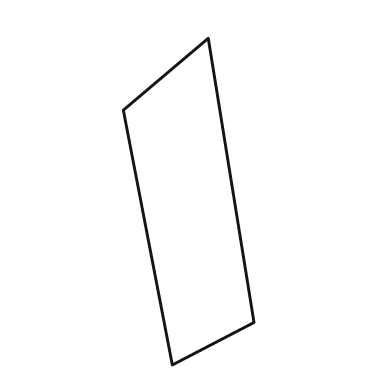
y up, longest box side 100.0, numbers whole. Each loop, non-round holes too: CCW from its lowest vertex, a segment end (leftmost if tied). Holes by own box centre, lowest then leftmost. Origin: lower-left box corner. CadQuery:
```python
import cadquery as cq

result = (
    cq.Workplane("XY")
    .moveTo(15.0, 0.0)
    .lineTo(40.0, 13.0)
    .lineTo(26.0, 100.0)
    .lineTo(0.0, 78.0)
    .close()
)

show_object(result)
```